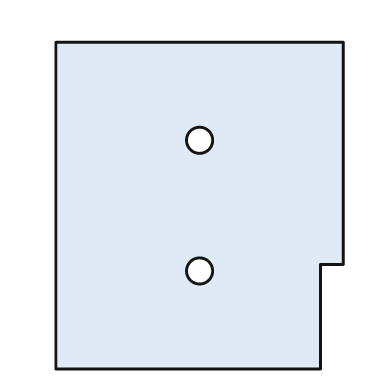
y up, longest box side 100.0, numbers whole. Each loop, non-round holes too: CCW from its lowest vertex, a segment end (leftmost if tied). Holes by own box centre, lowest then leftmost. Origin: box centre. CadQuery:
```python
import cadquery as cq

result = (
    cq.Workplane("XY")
    .moveTo(-44.0, -50.0)
    .lineTo(37.0, -50.0)
    .lineTo(37.0, -18.0)
    .lineTo(44.0, -18.0)
    .lineTo(44.0, 50.0)
    .lineTo(-44.0, 50.0)
    .close()
    .moveTo(0.0, -20.0)
    .circle(4.0)
    .moveTo(0.0, 20.0)
    .circle(4.0)
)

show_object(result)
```